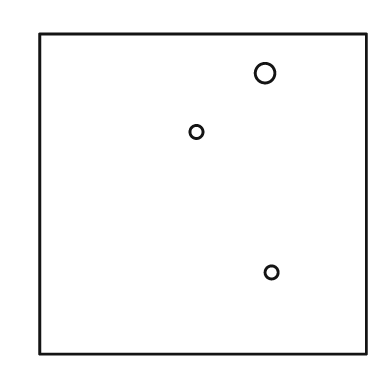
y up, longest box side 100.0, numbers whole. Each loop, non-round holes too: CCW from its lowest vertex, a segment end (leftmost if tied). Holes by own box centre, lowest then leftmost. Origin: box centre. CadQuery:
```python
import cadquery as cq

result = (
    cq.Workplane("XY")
    .moveTo(-50.0, -49.0)
    .lineTo(50.0, -49.0)
    .lineTo(50.0, 49.0)
    .lineTo(-50.0, 49.0)
    .close()
    .moveTo(21.0, -24.0)
    .circle(2.0)
    .moveTo(-2.0, 19.0)
    .circle(2.0)
    .moveTo(19.0, 37.0)
    .circle(3.0)
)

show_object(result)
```